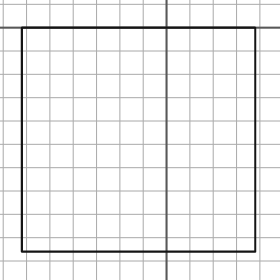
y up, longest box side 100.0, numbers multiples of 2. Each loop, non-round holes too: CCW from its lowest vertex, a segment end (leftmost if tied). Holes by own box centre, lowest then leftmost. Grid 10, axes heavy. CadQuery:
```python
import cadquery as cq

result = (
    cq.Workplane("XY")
    .moveTo(-62.0, -96.0)
    .lineTo(38.0, -96.0)
    .lineTo(38.0, 0.0)
    .lineTo(-62.0, 0.0)
    .close()
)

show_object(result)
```